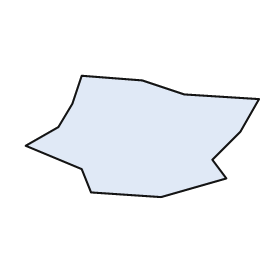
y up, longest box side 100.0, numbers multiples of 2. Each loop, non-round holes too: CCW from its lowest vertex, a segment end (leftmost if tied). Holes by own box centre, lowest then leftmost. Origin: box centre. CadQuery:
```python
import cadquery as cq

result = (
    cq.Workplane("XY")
    .moveTo(8.0, -26.0)
    .lineTo(36.0, -18.0)
    .lineTo(30.0, -10.0)
    .lineTo(42.0, 2.0)
    .lineTo(50.0, 16.0)
    .lineTo(18.0, 18.0)
    .lineTo(0.0, 24.0)
    .lineTo(-26.0, 26.0)
    .lineTo(-30.0, 14.0)
    .lineTo(-36.0, 4.0)
    .lineTo(-50.0, -4.0)
    .lineTo(-26.0, -14.0)
    .lineTo(-22.0, -24.0)
    .close()
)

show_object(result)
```